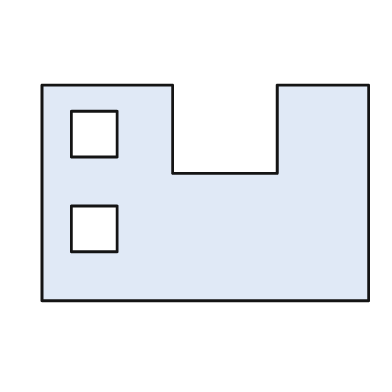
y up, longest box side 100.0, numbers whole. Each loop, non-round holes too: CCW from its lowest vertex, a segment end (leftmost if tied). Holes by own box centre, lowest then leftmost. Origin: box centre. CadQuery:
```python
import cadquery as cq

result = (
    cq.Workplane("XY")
    .moveTo(-50.0, -33.0)
    .lineTo(50.0, -33.0)
    .lineTo(50.0, 33.0)
    .lineTo(22.0, 33.0)
    .lineTo(22.0, 6.0)
    .lineTo(-10.0, 6.0)
    .lineTo(-10.0, 33.0)
    .lineTo(-50.0, 33.0)
    .close()
    .moveTo(-41.0, -18.0)
    .lineTo(-27.0, -18.0)
    .lineTo(-27.0, -4.0)
    .lineTo(-41.0, -4.0)
    .close()
    .moveTo(-41.0, 11.0)
    .lineTo(-27.0, 11.0)
    .lineTo(-27.0, 25.0)
    .lineTo(-41.0, 25.0)
    .close()
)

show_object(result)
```